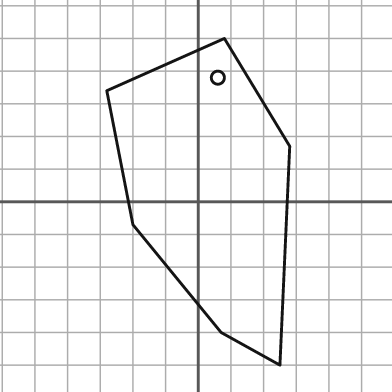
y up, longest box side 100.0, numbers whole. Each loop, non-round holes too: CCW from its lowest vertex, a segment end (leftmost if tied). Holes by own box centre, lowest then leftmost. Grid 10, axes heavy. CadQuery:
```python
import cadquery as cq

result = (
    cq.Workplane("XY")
    .moveTo(25.0, -50.0)
    .lineTo(28.0, 17.0)
    .lineTo(8.0, 50.0)
    .lineTo(-28.0, 34.0)
    .lineTo(-20.0, -7.0)
    .lineTo(7.0, -40.0)
    .close()
    .moveTo(6.0, 38.0)
    .circle(2.0)
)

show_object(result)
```